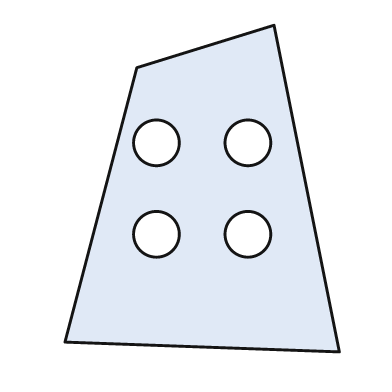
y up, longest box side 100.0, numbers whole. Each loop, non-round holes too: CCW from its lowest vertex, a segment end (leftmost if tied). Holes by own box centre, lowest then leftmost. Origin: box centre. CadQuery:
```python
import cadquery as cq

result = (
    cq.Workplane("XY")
    .moveTo(42.0, -50.0)
    .lineTo(22.0, 50.0)
    .lineTo(-20.0, 37.0)
    .lineTo(-42.0, -47.0)
    .close()
    .moveTo(-14.0, -14.0)
    .circle(7.0)
    .moveTo(14.0, -14.0)
    .circle(7.0)
    .moveTo(-14.0, 14.0)
    .circle(7.0)
    .moveTo(14.0, 14.0)
    .circle(7.0)
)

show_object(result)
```